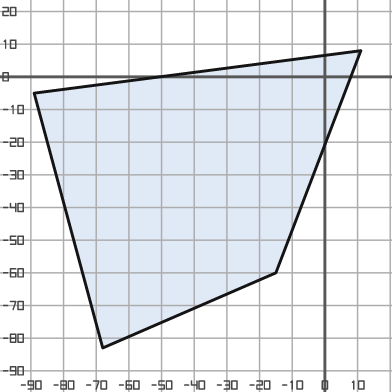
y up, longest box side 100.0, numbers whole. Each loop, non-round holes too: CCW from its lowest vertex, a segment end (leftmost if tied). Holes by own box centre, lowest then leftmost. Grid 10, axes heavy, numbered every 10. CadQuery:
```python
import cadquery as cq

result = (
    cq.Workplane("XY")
    .moveTo(-68.0, -83.0)
    .lineTo(-15.0, -60.0)
    .lineTo(11.0, 8.0)
    .lineTo(-89.0, -5.0)
    .close()
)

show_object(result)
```